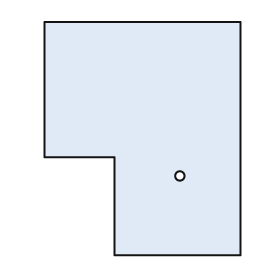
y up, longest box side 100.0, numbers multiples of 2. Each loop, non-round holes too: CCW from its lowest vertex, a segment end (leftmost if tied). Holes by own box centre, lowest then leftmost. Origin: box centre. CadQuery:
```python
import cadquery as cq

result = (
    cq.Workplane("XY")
    .moveTo(-12.0, -50.0)
    .lineTo(42.0, -50.0)
    .lineTo(42.0, 50.0)
    .lineTo(-42.0, 50.0)
    .lineTo(-42.0, -8.0)
    .lineTo(-12.0, -8.0)
    .close()
    .moveTo(16.0, -16.0)
    .circle(2.0)
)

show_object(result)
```